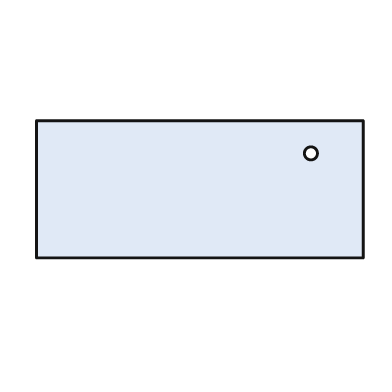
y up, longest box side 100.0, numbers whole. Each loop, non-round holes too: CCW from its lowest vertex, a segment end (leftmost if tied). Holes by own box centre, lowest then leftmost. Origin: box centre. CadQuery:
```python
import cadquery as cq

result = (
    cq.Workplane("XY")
    .moveTo(-50.0, -21.0)
    .lineTo(50.0, -21.0)
    .lineTo(50.0, 21.0)
    .lineTo(-50.0, 21.0)
    .close()
    .moveTo(34.0, 11.0)
    .circle(2.0)
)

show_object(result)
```